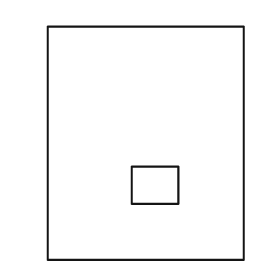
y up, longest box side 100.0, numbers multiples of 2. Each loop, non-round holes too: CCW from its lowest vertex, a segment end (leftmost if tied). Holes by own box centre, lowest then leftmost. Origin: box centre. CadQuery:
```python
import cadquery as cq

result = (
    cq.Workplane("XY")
    .moveTo(-42.0, -50.0)
    .lineTo(42.0, -50.0)
    .lineTo(42.0, 50.0)
    .lineTo(-42.0, 50.0)
    .close()
    .moveTo(-6.0, -26.0)
    .lineTo(14.0, -26.0)
    .lineTo(14.0, -10.0)
    .lineTo(-6.0, -10.0)
    .close()
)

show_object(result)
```